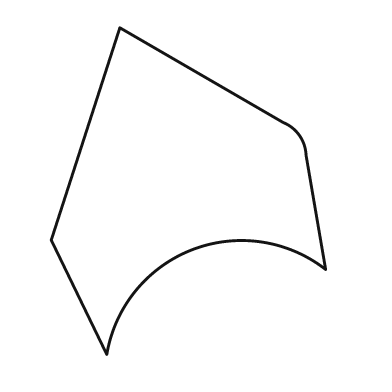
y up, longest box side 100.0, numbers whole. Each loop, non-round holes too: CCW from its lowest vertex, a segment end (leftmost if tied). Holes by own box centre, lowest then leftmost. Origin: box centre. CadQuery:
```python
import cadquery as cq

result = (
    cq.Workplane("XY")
    .moveTo(-25.0, -50.0)
    .threePointArc((1.0, -18.0), (42.0, -24.0))
    .lineTo(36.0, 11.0)
    .threePointArc((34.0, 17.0), (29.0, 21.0))
    .lineTo(-21.0, 50.0)
    .lineTo(-42.0, -15.0)
    .close()
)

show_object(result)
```